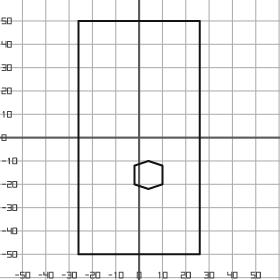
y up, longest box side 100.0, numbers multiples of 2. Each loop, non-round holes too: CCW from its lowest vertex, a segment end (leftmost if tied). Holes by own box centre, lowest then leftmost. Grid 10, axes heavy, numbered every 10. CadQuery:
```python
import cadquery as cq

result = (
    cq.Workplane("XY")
    .moveTo(-26.0, -50.0)
    .lineTo(26.0, -50.0)
    .lineTo(26.0, 50.0)
    .lineTo(-26.0, 50.0)
    .close()
    .moveTo(4.0, -22.0)
    .lineTo(10.0, -20.0)
    .lineTo(10.0, -12.0)
    .lineTo(4.0, -10.0)
    .lineTo(-2.0, -12.0)
    .lineTo(-2.0, -20.0)
    .close()
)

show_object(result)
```